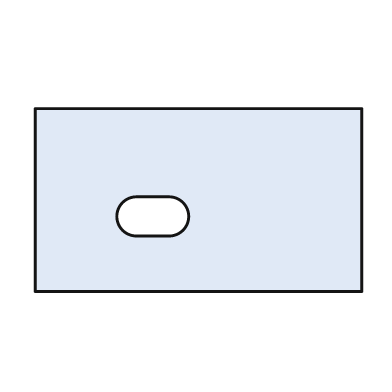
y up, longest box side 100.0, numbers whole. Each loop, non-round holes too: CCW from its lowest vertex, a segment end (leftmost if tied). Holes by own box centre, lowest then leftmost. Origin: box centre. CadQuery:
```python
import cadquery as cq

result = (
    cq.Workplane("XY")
    .moveTo(-50.0, -28.0)
    .lineTo(50.0, -28.0)
    .lineTo(50.0, 28.0)
    .lineTo(-50.0, 28.0)
    .close()
    .moveTo(-19.0, -11.0)
    .lineTo(-9.0, -11.0)
    .threePointArc((-3.0, -5.0), (-9.0, 1.0))
    .lineTo(-19.0, 1.0)
    .threePointArc((-25.0, -5.0), (-19.0, -11.0))
    .close()
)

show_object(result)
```